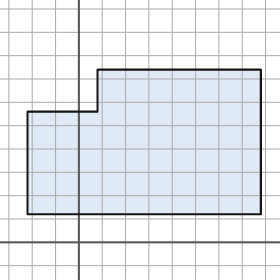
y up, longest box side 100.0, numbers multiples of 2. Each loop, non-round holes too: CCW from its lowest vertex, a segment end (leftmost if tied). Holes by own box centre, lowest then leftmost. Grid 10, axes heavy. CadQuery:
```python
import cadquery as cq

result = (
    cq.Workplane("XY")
    .moveTo(-22.0, 12.0)
    .lineTo(78.0, 12.0)
    .lineTo(78.0, 74.0)
    .lineTo(8.0, 74.0)
    .lineTo(8.0, 56.0)
    .lineTo(-22.0, 56.0)
    .close()
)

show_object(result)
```